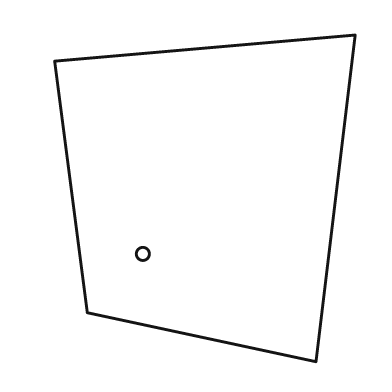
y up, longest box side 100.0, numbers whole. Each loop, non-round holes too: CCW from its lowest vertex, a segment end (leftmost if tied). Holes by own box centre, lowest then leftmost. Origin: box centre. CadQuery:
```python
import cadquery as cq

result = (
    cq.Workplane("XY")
    .moveTo(34.0, -50.0)
    .lineTo(46.0, 50.0)
    .lineTo(-46.0, 42.0)
    .lineTo(-36.0, -35.0)
    .close()
    .moveTo(-19.0, -17.0)
    .circle(2.0)
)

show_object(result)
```